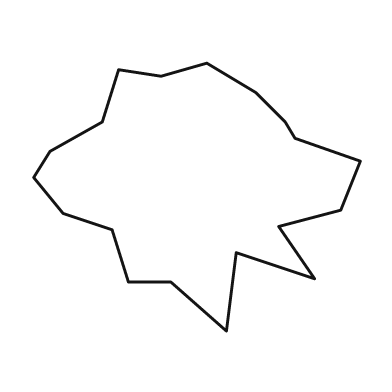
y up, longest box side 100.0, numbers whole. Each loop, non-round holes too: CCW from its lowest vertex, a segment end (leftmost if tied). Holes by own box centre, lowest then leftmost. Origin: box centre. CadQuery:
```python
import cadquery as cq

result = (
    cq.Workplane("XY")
    .moveTo(9.0, -41.0)
    .lineTo(12.0, -17.0)
    .lineTo(36.0, -25.0)
    .lineTo(25.0, -9.0)
    .lineTo(44.0, -4.0)
    .lineTo(50.0, 11.0)
    .lineTo(30.0, 18.0)
    .lineTo(27.0, 23.0)
    .lineTo(18.0, 32.0)
    .lineTo(3.0, 41.0)
    .lineTo(-11.0, 37.0)
    .lineTo(-24.0, 39.0)
    .lineTo(-29.0, 23.0)
    .lineTo(-45.0, 14.0)
    .lineTo(-50.0, 6.0)
    .lineTo(-41.0, -5.0)
    .lineTo(-26.0, -10.0)
    .lineTo(-21.0, -26.0)
    .lineTo(-8.0, -26.0)
    .close()
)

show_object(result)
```